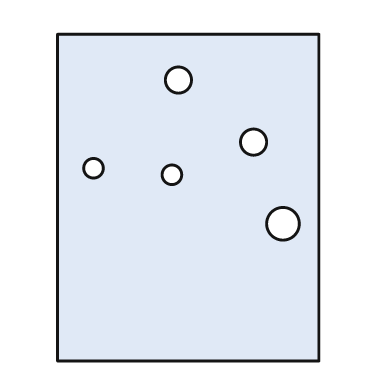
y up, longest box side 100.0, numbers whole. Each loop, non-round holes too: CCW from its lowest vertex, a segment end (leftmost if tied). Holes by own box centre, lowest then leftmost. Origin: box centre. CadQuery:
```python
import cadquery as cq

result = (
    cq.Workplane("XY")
    .moveTo(-40.0, -50.0)
    .lineTo(40.0, -50.0)
    .lineTo(40.0, 50.0)
    .lineTo(-40.0, 50.0)
    .close()
    .moveTo(29.0, -8.0)
    .circle(5.0)
    .moveTo(-5.0, 7.0)
    .circle(3.0)
    .moveTo(-29.0, 9.0)
    .circle(3.0)
    .moveTo(20.0, 17.0)
    .circle(4.0)
    .moveTo(-3.0, 36.0)
    .circle(4.0)
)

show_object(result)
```